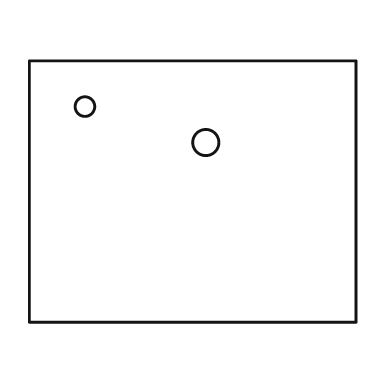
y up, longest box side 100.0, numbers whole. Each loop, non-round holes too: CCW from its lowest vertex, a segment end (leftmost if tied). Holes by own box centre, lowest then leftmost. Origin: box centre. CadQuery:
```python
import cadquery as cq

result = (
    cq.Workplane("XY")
    .moveTo(-50.0, -40.0)
    .lineTo(50.0, -40.0)
    .lineTo(50.0, 40.0)
    .lineTo(-50.0, 40.0)
    .close()
    .moveTo(4.0, 15.0)
    .circle(4.0)
    .moveTo(-33.0, 26.0)
    .circle(3.0)
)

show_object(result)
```